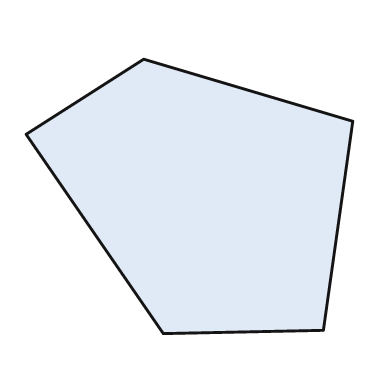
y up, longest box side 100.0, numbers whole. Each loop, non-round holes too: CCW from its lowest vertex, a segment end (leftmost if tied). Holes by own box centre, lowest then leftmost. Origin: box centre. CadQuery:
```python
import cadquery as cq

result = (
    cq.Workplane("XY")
    .moveTo(-8.0, -42.0)
    .lineTo(41.0, -41.0)
    .lineTo(50.0, 23.0)
    .lineTo(-14.0, 42.0)
    .lineTo(-50.0, 19.0)
    .close()
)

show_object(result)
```